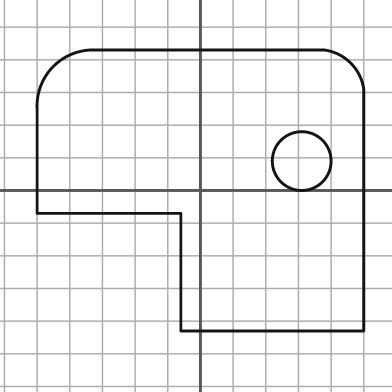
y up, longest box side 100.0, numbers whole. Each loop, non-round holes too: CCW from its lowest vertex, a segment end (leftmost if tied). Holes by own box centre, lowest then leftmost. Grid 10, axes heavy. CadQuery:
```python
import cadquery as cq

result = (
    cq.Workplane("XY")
    .moveTo(-6.0, -43.0)
    .lineTo(50.0, -43.0)
    .lineTo(50.0, 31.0)
    .threePointArc((46.0, 39.0), (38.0, 43.0))
    .lineTo(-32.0, 43.0)
    .threePointArc((-45.0, 38.0), (-50.0, 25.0))
    .lineTo(-50.0, -7.0)
    .lineTo(-6.0, -7.0)
    .close()
    .moveTo(31.0, 9.0)
    .circle(9.0)
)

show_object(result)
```